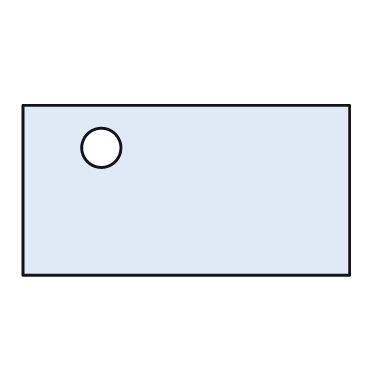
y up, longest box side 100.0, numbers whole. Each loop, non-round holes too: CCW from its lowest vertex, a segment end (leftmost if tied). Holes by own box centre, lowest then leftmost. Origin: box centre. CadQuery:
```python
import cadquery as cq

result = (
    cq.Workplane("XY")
    .moveTo(-50.0, -26.0)
    .lineTo(50.0, -26.0)
    .lineTo(50.0, 26.0)
    .lineTo(-50.0, 26.0)
    .close()
    .moveTo(-26.0, 13.0)
    .circle(6.0)
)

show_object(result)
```